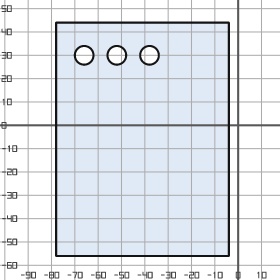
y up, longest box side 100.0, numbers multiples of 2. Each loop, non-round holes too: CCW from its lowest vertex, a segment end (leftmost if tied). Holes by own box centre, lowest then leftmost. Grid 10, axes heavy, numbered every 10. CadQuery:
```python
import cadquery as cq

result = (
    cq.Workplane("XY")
    .moveTo(-78.0, -56.0)
    .lineTo(-4.0, -56.0)
    .lineTo(-4.0, 44.0)
    .lineTo(-78.0, 44.0)
    .close()
    .moveTo(-66.0, 30.0)
    .circle(4.0)
    .moveTo(-52.0, 30.0)
    .circle(4.0)
    .moveTo(-38.0, 30.0)
    .circle(4.0)
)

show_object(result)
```